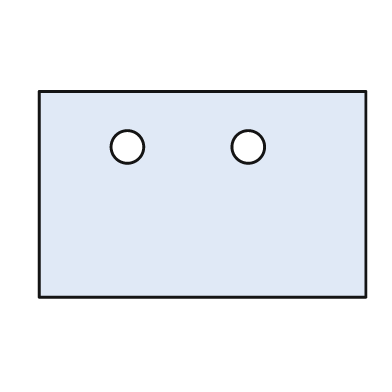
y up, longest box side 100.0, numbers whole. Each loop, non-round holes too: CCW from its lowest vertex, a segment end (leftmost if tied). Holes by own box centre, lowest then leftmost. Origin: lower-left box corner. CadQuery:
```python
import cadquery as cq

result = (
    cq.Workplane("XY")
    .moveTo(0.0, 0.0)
    .lineTo(100.0, 0.0)
    .lineTo(100.0, 63.0)
    .lineTo(0.0, 63.0)
    .close()
    .moveTo(27.0, 46.0)
    .circle(5.0)
    .moveTo(64.0, 46.0)
    .circle(5.0)
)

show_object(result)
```